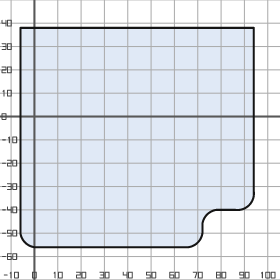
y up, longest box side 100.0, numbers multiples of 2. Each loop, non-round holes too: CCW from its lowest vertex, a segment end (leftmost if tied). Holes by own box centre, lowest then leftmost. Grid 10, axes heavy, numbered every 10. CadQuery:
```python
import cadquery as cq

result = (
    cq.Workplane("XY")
    .moveTo(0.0, -56.0)
    .lineTo(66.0, -56.0)
    .threePointArc((70.0, -54.0), (72.0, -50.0))
    .lineTo(72.0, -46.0)
    .threePointArc((74.0, -42.0), (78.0, -40.0))
    .lineTo(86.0, -40.0)
    .threePointArc((92.0, -38.0), (94.0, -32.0))
    .lineTo(94.0, 38.0)
    .lineTo(-6.0, 38.0)
    .lineTo(-6.0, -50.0)
    .threePointArc((-4.0, -54.0), (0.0, -56.0))
    .close()
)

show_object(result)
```